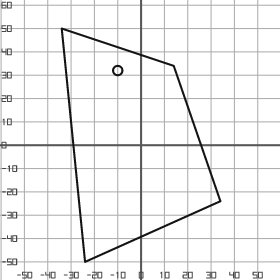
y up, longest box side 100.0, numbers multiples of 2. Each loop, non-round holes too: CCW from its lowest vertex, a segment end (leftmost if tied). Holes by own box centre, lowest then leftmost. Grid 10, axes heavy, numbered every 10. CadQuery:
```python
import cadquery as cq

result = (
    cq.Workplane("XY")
    .moveTo(-24.0, -50.0)
    .lineTo(34.0, -24.0)
    .lineTo(14.0, 34.0)
    .lineTo(-34.0, 50.0)
    .close()
    .moveTo(-10.0, 32.0)
    .circle(2.0)
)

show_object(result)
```